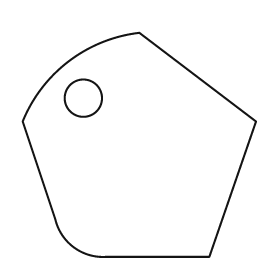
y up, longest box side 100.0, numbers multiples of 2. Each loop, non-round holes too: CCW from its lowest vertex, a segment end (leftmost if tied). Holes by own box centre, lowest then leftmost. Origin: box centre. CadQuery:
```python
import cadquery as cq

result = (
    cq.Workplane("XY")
    .moveTo(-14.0, -48.0)
    .lineTo(30.0, -48.0)
    .lineTo(50.0, 10.0)
    .lineTo(0.0, 48.0)
    .threePointArc((-30.0, 36.0), (-50.0, 10.0))
    .lineTo(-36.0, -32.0)
    .threePointArc((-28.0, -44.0), (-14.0, -48.0))
    .close()
    .moveTo(-24.0, 20.0)
    .circle(8.0)
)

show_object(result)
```